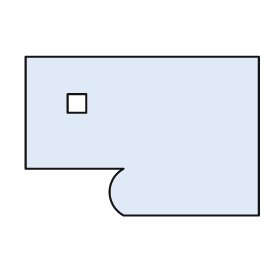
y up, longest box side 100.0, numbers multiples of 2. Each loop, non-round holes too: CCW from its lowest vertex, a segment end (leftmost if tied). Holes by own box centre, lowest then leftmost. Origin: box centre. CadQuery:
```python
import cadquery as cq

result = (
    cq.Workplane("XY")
    .moveTo(-8.0, -34.0)
    .lineTo(50.0, -34.0)
    .lineTo(50.0, 34.0)
    .lineTo(-50.0, 34.0)
    .lineTo(-50.0, -14.0)
    .lineTo(-8.0, -14.0)
    .threePointArc((-14.0, -24.0), (-8.0, -34.0))
    .close()
    .moveTo(-32.0, 10.0)
    .lineTo(-24.0, 10.0)
    .lineTo(-24.0, 18.0)
    .lineTo(-32.0, 18.0)
    .close()
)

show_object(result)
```